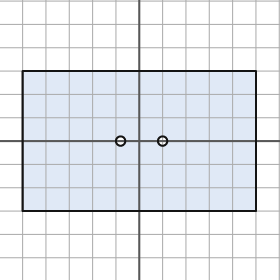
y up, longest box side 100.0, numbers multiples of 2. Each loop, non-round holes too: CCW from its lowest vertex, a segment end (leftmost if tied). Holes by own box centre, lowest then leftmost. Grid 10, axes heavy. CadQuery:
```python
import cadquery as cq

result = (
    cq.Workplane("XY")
    .moveTo(-50.0, -30.0)
    .lineTo(50.0, -30.0)
    .lineTo(50.0, 30.0)
    .lineTo(-50.0, 30.0)
    .close()
    .moveTo(-8.0, 0.0)
    .circle(2.0)
    .moveTo(10.0, 0.0)
    .circle(2.0)
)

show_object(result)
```